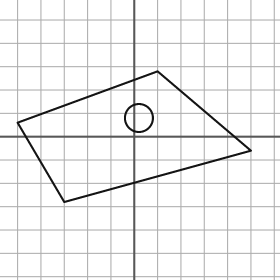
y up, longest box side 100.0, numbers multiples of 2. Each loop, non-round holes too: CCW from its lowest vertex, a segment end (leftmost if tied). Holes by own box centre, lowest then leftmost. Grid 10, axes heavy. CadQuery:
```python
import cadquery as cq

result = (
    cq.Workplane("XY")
    .moveTo(-30.0, -28.0)
    .lineTo(50.0, -6.0)
    .lineTo(10.0, 28.0)
    .lineTo(-50.0, 6.0)
    .close()
    .moveTo(2.0, 8.0)
    .circle(6.0)
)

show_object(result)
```